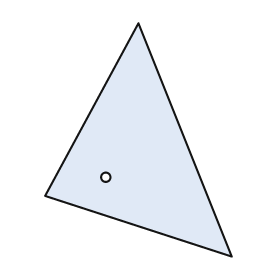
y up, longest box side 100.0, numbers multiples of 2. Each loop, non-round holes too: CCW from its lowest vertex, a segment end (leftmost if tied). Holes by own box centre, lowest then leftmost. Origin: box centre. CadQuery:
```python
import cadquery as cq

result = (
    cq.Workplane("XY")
    .moveTo(40.0, -50.0)
    .lineTo(0.0, 50.0)
    .lineTo(-40.0, -24.0)
    .close()
    .moveTo(-14.0, -16.0)
    .circle(2.0)
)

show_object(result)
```